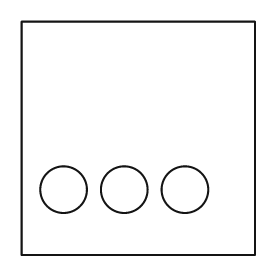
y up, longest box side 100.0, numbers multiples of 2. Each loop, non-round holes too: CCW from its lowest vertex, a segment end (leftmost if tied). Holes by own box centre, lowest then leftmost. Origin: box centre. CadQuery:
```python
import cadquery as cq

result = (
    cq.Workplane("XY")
    .moveTo(-50.0, -50.0)
    .lineTo(50.0, -50.0)
    .lineTo(50.0, 50.0)
    .lineTo(-50.0, 50.0)
    .close()
    .moveTo(-32.0, -22.0)
    .circle(10.0)
    .moveTo(-6.0, -22.0)
    .circle(10.0)
    .moveTo(20.0, -22.0)
    .circle(10.0)
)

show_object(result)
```